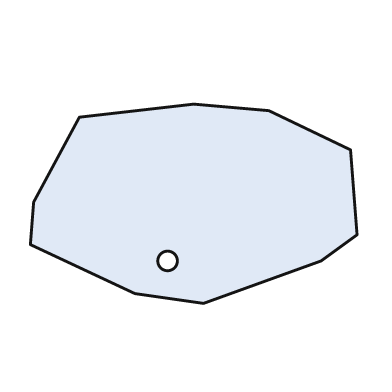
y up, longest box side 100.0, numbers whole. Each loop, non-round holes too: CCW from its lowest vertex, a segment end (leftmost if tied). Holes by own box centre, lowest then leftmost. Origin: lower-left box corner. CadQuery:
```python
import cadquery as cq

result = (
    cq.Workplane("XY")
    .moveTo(53.0, 0.0)
    .lineTo(89.0, 13.0)
    .lineTo(100.0, 21.0)
    .lineTo(98.0, 47.0)
    .lineTo(73.0, 59.0)
    .lineTo(50.0, 61.0)
    .lineTo(15.0, 57.0)
    .lineTo(1.0, 31.0)
    .lineTo(0.0, 18.0)
    .lineTo(32.0, 3.0)
    .close()
    .moveTo(42.0, 13.0)
    .circle(3.0)
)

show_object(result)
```